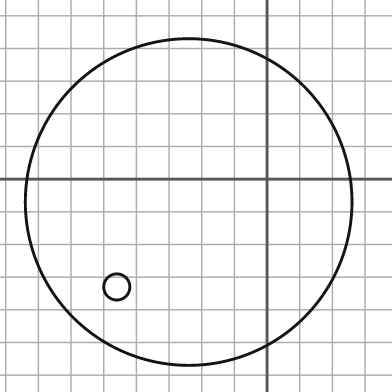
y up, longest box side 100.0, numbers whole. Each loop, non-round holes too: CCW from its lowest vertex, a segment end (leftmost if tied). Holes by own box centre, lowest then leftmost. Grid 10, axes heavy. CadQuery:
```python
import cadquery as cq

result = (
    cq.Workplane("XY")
    .moveTo(-24.0, -7.0)
    .circle(50.0)
    .moveTo(-46.0, -33.0)
    .circle(4.0)
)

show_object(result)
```